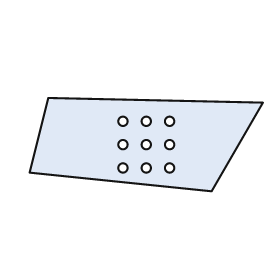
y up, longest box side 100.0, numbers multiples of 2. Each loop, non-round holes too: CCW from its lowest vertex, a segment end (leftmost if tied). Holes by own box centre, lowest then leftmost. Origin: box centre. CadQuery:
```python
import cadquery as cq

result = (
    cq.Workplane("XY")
    .moveTo(28.0, -20.0)
    .lineTo(50.0, 18.0)
    .lineTo(-42.0, 20.0)
    .lineTo(-50.0, -12.0)
    .close()
    .moveTo(-10.0, -10.0)
    .circle(2.0)
    .moveTo(0.0, -10.0)
    .circle(2.0)
    .moveTo(10.0, -10.0)
    .circle(2.0)
    .moveTo(-10.0, 0.0)
    .circle(2.0)
    .moveTo(0.0, 0.0)
    .circle(2.0)
    .moveTo(10.0, 0.0)
    .circle(2.0)
    .moveTo(-10.0, 10.0)
    .circle(2.0)
    .moveTo(0.0, 10.0)
    .circle(2.0)
    .moveTo(10.0, 10.0)
    .circle(2.0)
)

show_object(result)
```